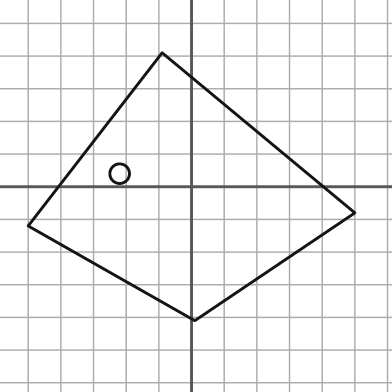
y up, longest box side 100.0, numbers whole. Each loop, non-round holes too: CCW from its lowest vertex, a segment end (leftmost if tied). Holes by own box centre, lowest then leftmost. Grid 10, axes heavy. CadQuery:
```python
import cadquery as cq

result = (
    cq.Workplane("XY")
    .moveTo(1.0, -41.0)
    .lineTo(50.0, -8.0)
    .lineTo(-9.0, 41.0)
    .lineTo(-50.0, -12.0)
    .close()
    .moveTo(-22.0, 4.0)
    .circle(3.0)
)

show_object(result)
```